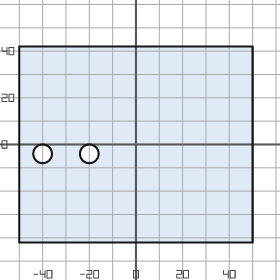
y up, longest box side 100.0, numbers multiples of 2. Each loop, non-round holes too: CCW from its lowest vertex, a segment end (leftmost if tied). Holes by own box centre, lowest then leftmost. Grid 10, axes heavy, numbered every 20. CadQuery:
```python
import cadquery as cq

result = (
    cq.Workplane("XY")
    .moveTo(-50.0, -42.0)
    .lineTo(50.0, -42.0)
    .lineTo(50.0, 42.0)
    .lineTo(-50.0, 42.0)
    .close()
    .moveTo(-40.0, -4.0)
    .circle(4.0)
    .moveTo(-20.0, -4.0)
    .circle(4.0)
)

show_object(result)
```